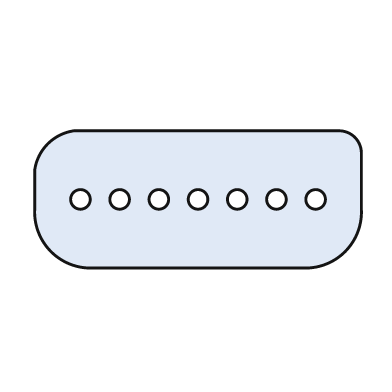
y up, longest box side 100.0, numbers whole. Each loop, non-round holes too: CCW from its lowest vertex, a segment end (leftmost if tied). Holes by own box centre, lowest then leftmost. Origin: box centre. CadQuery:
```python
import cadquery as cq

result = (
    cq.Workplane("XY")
    .moveTo(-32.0, -21.0)
    .lineTo(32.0, -21.0)
    .threePointArc((45.0, -16.0), (50.0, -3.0))
    .lineTo(50.0, 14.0)
    .threePointArc((48.0, 19.0), (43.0, 21.0))
    .lineTo(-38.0, 21.0)
    .threePointArc((-46.0, 17.0), (-50.0, 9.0))
    .lineTo(-50.0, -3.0)
    .threePointArc((-45.0, -16.0), (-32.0, -21.0))
    .close()
    .moveTo(-36.0, 0.0)
    .circle(3.0)
    .moveTo(-24.0, 0.0)
    .circle(3.0)
    .moveTo(-12.0, 0.0)
    .circle(3.0)
    .moveTo(0.0, 0.0)
    .circle(3.0)
    .moveTo(12.0, 0.0)
    .circle(3.0)
    .moveTo(24.0, 0.0)
    .circle(3.0)
    .moveTo(36.0, 0.0)
    .circle(3.0)
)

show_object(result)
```